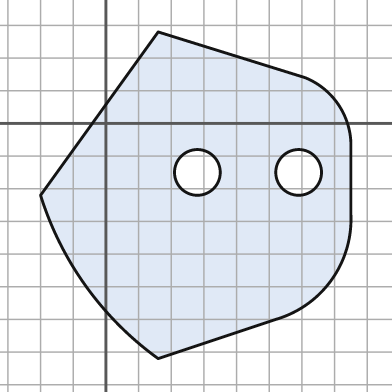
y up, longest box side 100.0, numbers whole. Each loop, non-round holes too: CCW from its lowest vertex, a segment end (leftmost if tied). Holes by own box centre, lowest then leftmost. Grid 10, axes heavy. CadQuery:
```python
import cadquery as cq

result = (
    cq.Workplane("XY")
    .moveTo(16.0, -72.0)
    .lineTo(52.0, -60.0)
    .threePointArc((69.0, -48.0), (75.0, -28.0))
    .lineTo(75.0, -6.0)
    .threePointArc((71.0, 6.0), (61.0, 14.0))
    .lineTo(16.0, 28.0)
    .lineTo(-20.0, -22.0)
    .threePointArc((-6.0, -50.0), (16.0, -72.0))
    .close()
    .moveTo(28.0, -15.0)
    .circle(7.0)
    .moveTo(59.0, -15.0)
    .circle(7.0)
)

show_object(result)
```